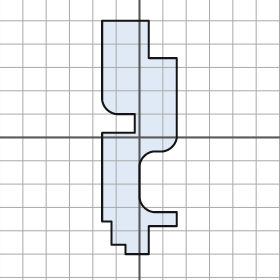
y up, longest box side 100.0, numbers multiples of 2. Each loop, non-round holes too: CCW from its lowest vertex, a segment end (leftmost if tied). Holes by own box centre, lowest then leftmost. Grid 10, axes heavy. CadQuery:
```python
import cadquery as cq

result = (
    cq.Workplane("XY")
    .moveTo(-6.0, -50.0)
    .lineTo(4.0, -50.0)
    .lineTo(4.0, -38.0)
    .lineTo(16.0, -38.0)
    .lineTo(16.0, -32.0)
    .lineTo(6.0, -32.0)
    .threePointArc((2.0, -30.0), (0.0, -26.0))
    .lineTo(0.0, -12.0)
    .threePointArc((2.0, -8.0), (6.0, -6.0))
    .lineTo(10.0, -6.0)
    .threePointArc((14.0, -4.0), (16.0, 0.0))
    .lineTo(16.0, 34.0)
    .lineTo(4.0, 34.0)
    .lineTo(4.0, 50.0)
    .lineTo(-16.0, 50.0)
    .lineTo(-16.0, 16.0)
    .threePointArc((-14.0, 12.0), (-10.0, 10.0))
    .lineTo(-2.0, 10.0)
    .lineTo(-2.0, 2.0)
    .lineTo(-16.0, 2.0)
    .lineTo(-16.0, -36.0)
    .lineTo(-12.0, -36.0)
    .lineTo(-12.0, -46.0)
    .lineTo(-6.0, -46.0)
    .close()
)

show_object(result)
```